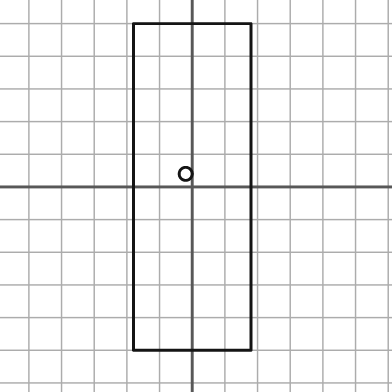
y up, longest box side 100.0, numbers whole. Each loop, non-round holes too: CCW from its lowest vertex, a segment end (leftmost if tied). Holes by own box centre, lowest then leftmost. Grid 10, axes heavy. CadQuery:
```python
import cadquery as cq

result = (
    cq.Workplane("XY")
    .moveTo(-18.0, -50.0)
    .lineTo(18.0, -50.0)
    .lineTo(18.0, 50.0)
    .lineTo(-18.0, 50.0)
    .close()
    .moveTo(-2.0, 4.0)
    .circle(2.0)
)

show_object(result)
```